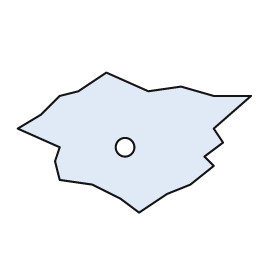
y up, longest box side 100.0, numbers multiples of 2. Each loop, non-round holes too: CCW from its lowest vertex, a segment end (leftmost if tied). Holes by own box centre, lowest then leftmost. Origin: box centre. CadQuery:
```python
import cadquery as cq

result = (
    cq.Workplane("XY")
    .moveTo(2.0, -30.0)
    .lineTo(14.0, -22.0)
    .lineTo(24.0, -18.0)
    .lineTo(34.0, -10.0)
    .lineTo(30.0, -6.0)
    .lineTo(38.0, 0.0)
    .lineTo(34.0, 6.0)
    .lineTo(50.0, 20.0)
    .lineTo(34.0, 20.0)
    .lineTo(20.0, 24.0)
    .lineTo(6.0, 22.0)
    .lineTo(-12.0, 30.0)
    .lineTo(-24.0, 22.0)
    .lineTo(-32.0, 20.0)
    .lineTo(-40.0, 12.0)
    .lineTo(-50.0, 6.0)
    .lineTo(-32.0, -2.0)
    .lineTo(-34.0, -8.0)
    .lineTo(-32.0, -16.0)
    .lineTo(-18.0, -18.0)
    .lineTo(-6.0, -24.0)
    .close()
    .moveTo(-4.0, -2.0)
    .circle(4.0)
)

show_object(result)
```